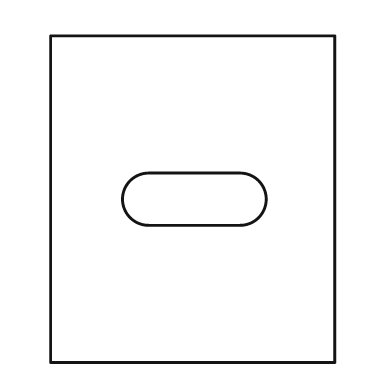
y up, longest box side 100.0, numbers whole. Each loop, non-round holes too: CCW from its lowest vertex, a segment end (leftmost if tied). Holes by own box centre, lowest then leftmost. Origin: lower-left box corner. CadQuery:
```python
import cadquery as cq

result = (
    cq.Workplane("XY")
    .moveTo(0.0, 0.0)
    .lineTo(87.0, 0.0)
    .lineTo(87.0, 100.0)
    .lineTo(0.0, 100.0)
    .close()
    .moveTo(30.0, 42.0)
    .lineTo(58.0, 42.0)
    .threePointArc((66.0, 50.0), (58.0, 58.0))
    .lineTo(30.0, 58.0)
    .threePointArc((22.0, 50.0), (30.0, 42.0))
    .close()
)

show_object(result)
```